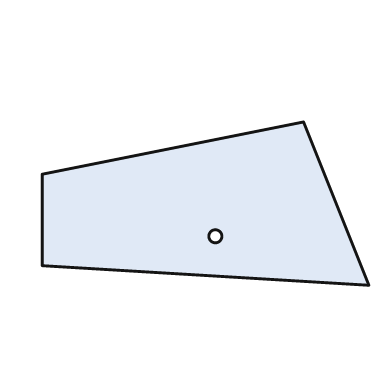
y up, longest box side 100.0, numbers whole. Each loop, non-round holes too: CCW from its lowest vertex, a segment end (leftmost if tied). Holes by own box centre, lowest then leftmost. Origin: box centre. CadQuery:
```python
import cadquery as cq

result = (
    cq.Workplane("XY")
    .moveTo(50.0, -25.0)
    .lineTo(30.0, 25.0)
    .lineTo(-50.0, 9.0)
    .lineTo(-50.0, -19.0)
    .close()
    .moveTo(3.0, -10.0)
    .circle(2.0)
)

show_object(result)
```